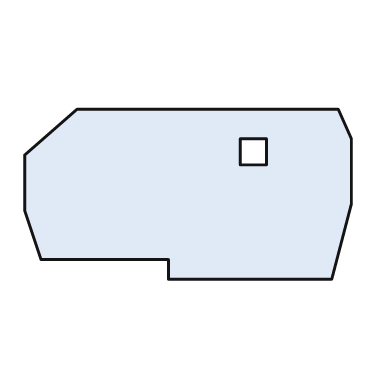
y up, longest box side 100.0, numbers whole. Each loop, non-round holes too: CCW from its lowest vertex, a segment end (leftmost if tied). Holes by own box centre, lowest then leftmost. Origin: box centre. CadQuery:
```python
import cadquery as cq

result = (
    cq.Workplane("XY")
    .moveTo(-6.0, -26.0)
    .lineTo(44.0, -26.0)
    .lineTo(50.0, -3.0)
    .lineTo(50.0, 17.0)
    .lineTo(46.0, 26.0)
    .lineTo(-34.0, 26.0)
    .lineTo(-50.0, 12.0)
    .lineTo(-50.0, -5.0)
    .lineTo(-45.0, -20.0)
    .lineTo(-6.0, -20.0)
    .close()
    .moveTo(16.0, 9.0)
    .lineTo(24.0, 9.0)
    .lineTo(24.0, 17.0)
    .lineTo(16.0, 17.0)
    .close()
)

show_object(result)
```